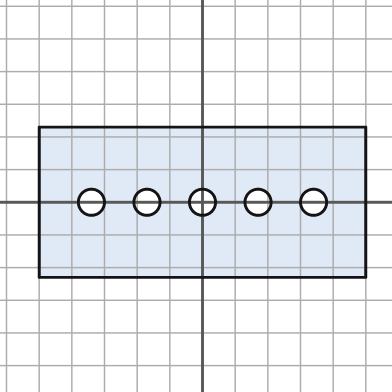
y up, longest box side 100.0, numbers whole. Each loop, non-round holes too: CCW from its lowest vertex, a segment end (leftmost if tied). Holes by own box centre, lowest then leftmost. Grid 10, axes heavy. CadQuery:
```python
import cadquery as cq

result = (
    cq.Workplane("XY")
    .moveTo(-50.0, -23.0)
    .lineTo(50.0, -23.0)
    .lineTo(50.0, 23.0)
    .lineTo(-50.0, 23.0)
    .close()
    .moveTo(-34.0, 0.0)
    .circle(4.0)
    .moveTo(-17.0, 0.0)
    .circle(4.0)
    .moveTo(0.0, 0.0)
    .circle(4.0)
    .moveTo(17.0, 0.0)
    .circle(4.0)
    .moveTo(34.0, 0.0)
    .circle(4.0)
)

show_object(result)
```